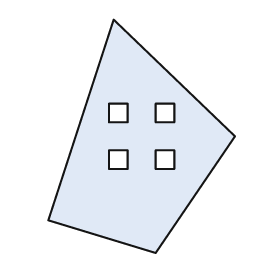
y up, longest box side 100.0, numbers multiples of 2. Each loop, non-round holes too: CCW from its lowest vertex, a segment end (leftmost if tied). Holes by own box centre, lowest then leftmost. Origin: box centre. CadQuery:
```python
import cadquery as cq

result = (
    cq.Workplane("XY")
    .moveTo(6.0, -50.0)
    .lineTo(40.0, 0.0)
    .lineTo(-12.0, 50.0)
    .lineTo(-40.0, -36.0)
    .close()
    .moveTo(-14.0, -14.0)
    .lineTo(-6.0, -14.0)
    .lineTo(-6.0, -6.0)
    .lineTo(-14.0, -6.0)
    .close()
    .moveTo(6.0, -14.0)
    .lineTo(14.0, -14.0)
    .lineTo(14.0, -6.0)
    .lineTo(6.0, -6.0)
    .close()
    .moveTo(-14.0, 6.0)
    .lineTo(-6.0, 6.0)
    .lineTo(-6.0, 14.0)
    .lineTo(-14.0, 14.0)
    .close()
    .moveTo(6.0, 6.0)
    .lineTo(14.0, 6.0)
    .lineTo(14.0, 14.0)
    .lineTo(6.0, 14.0)
    .close()
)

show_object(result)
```